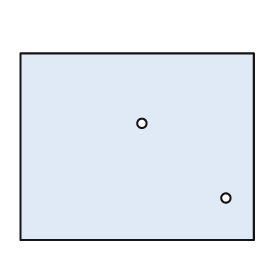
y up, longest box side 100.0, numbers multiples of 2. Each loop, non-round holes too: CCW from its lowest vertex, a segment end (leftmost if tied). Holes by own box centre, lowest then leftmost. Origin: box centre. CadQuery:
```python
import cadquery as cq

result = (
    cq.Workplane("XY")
    .moveTo(-50.0, -40.0)
    .lineTo(50.0, -40.0)
    .lineTo(50.0, 40.0)
    .lineTo(-50.0, 40.0)
    .close()
    .moveTo(38.0, -22.0)
    .circle(2.0)
    .moveTo(2.0, 10.0)
    .circle(2.0)
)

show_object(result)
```